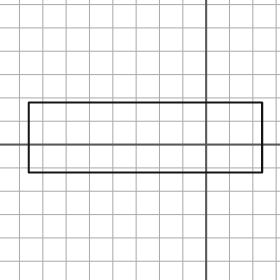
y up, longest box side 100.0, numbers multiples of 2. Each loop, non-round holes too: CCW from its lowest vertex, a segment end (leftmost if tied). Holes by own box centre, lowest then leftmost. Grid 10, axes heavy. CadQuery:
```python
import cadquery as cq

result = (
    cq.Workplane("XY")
    .moveTo(-76.0, -12.0)
    .lineTo(24.0, -12.0)
    .lineTo(24.0, 18.0)
    .lineTo(-76.0, 18.0)
    .close()
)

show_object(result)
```